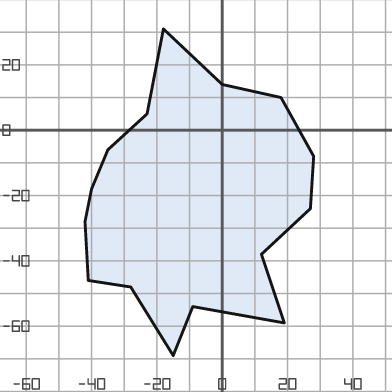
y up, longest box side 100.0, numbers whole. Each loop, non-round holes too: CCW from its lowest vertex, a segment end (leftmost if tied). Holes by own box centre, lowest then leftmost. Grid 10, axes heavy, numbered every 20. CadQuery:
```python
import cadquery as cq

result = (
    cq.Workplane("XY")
    .moveTo(-15.0, -69.0)
    .lineTo(-9.0, -54.0)
    .lineTo(19.0, -59.0)
    .lineTo(12.0, -38.0)
    .lineTo(27.0, -24.0)
    .lineTo(28.0, -8.0)
    .lineTo(18.0, 10.0)
    .lineTo(0.0, 14.0)
    .lineTo(-18.0, 31.0)
    .lineTo(-23.0, 5.0)
    .lineTo(-35.0, -6.0)
    .lineTo(-40.0, -18.0)
    .lineTo(-42.0, -28.0)
    .lineTo(-41.0, -46.0)
    .lineTo(-28.0, -48.0)
    .close()
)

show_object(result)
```